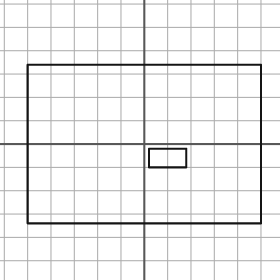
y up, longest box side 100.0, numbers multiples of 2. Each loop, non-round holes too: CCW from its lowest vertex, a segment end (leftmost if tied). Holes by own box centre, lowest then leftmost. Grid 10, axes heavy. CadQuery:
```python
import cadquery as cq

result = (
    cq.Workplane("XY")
    .moveTo(-50.0, -34.0)
    .lineTo(50.0, -34.0)
    .lineTo(50.0, 34.0)
    .lineTo(-50.0, 34.0)
    .close()
    .moveTo(2.0, -10.0)
    .lineTo(18.0, -10.0)
    .lineTo(18.0, -2.0)
    .lineTo(2.0, -2.0)
    .close()
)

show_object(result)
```